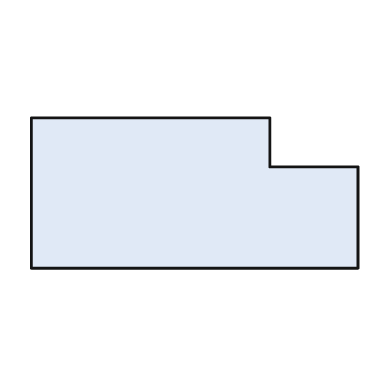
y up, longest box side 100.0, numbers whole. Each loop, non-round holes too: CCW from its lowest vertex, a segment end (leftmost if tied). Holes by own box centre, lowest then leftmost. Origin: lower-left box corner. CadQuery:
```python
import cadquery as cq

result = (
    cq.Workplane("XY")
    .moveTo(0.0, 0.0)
    .lineTo(100.0, 0.0)
    .lineTo(100.0, 31.0)
    .lineTo(73.0, 31.0)
    .lineTo(73.0, 46.0)
    .lineTo(0.0, 46.0)
    .close()
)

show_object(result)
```